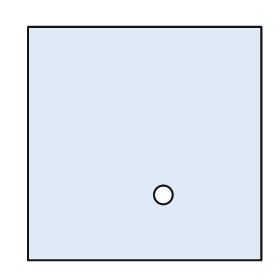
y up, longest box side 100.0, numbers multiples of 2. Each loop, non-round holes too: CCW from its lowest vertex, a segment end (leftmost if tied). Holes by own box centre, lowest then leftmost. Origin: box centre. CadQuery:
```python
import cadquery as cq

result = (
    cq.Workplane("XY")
    .moveTo(-50.0, -50.0)
    .lineTo(50.0, -50.0)
    .lineTo(50.0, 50.0)
    .lineTo(-50.0, 50.0)
    .close()
    .moveTo(8.0, -22.0)
    .circle(4.0)
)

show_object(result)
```